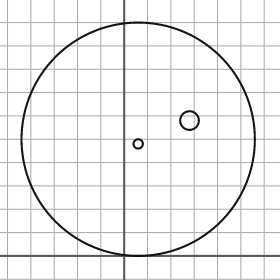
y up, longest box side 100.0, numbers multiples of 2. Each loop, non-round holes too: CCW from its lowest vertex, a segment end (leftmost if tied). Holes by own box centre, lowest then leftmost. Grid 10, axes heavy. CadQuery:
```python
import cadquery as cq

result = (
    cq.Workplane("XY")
    .moveTo(6.0, 50.0)
    .circle(50.0)
    .moveTo(6.0, 48.0)
    .circle(2.0)
    .moveTo(28.0, 58.0)
    .circle(4.0)
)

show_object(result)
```